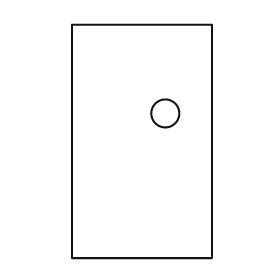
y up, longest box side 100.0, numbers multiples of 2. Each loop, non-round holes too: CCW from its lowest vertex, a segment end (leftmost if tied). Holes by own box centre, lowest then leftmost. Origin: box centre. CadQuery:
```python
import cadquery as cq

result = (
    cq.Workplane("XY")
    .moveTo(-30.0, -50.0)
    .lineTo(30.0, -50.0)
    .lineTo(30.0, 50.0)
    .lineTo(-30.0, 50.0)
    .close()
    .moveTo(10.0, 12.0)
    .circle(6.0)
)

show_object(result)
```